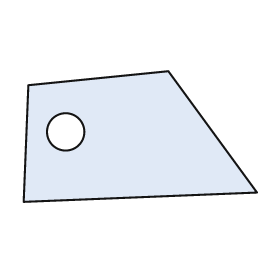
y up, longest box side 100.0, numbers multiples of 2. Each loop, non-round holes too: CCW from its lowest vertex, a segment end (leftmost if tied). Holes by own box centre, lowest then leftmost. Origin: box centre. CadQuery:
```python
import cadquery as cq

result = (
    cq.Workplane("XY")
    .moveTo(-50.0, -28.0)
    .lineTo(50.0, -24.0)
    .lineTo(12.0, 28.0)
    .lineTo(-48.0, 22.0)
    .close()
    .moveTo(-32.0, 2.0)
    .circle(8.0)
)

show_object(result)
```